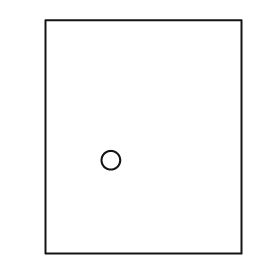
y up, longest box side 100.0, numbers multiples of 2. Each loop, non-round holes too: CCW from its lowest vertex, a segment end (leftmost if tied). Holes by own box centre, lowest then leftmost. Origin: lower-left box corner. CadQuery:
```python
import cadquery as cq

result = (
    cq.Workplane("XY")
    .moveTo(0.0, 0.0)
    .lineTo(84.0, 0.0)
    .lineTo(84.0, 100.0)
    .lineTo(0.0, 100.0)
    .close()
    .moveTo(28.0, 40.0)
    .circle(4.0)
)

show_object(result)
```